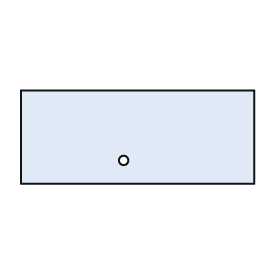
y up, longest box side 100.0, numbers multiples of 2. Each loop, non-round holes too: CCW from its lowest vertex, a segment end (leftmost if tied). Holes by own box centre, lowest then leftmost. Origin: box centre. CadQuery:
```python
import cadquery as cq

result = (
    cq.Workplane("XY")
    .moveTo(-50.0, -20.0)
    .lineTo(50.0, -20.0)
    .lineTo(50.0, 20.0)
    .lineTo(-50.0, 20.0)
    .close()
    .moveTo(-6.0, -10.0)
    .circle(2.0)
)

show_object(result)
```